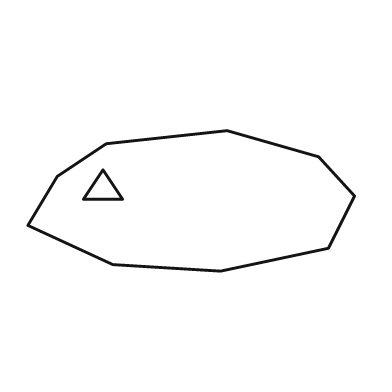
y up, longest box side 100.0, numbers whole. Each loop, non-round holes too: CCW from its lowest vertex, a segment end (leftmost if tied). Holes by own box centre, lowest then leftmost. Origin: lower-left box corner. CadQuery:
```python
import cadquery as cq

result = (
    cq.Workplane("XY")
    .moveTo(59.0, 0.0)
    .lineTo(92.0, 7.0)
    .lineTo(100.0, 23.0)
    .lineTo(89.0, 35.0)
    .lineTo(61.0, 43.0)
    .lineTo(24.0, 39.0)
    .lineTo(9.0, 29.0)
    .lineTo(0.0, 14.0)
    .lineTo(26.0, 2.0)
    .close()
    .moveTo(17.0, 22.0)
    .lineTo(29.0, 22.0)
    .lineTo(23.0, 31.0)
    .close()
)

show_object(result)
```